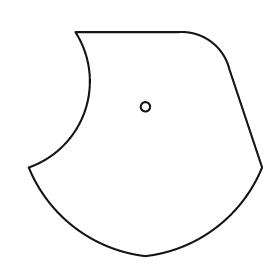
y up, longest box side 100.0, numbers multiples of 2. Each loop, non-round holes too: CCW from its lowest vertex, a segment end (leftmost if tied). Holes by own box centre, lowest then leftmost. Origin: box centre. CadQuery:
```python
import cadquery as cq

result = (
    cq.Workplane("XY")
    .moveTo(0.0, -48.0)
    .threePointArc((30.0, -36.0), (50.0, -10.0))
    .lineTo(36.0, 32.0)
    .threePointArc((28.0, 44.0), (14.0, 48.0))
    .lineTo(-30.0, 48.0)
    .threePointArc((-26.0, 14.0), (-50.0, -10.0))
    .threePointArc((-30.0, -36.0), (0.0, -48.0))
    .close()
    .moveTo(0.0, 16.0)
    .circle(2.0)
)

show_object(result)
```